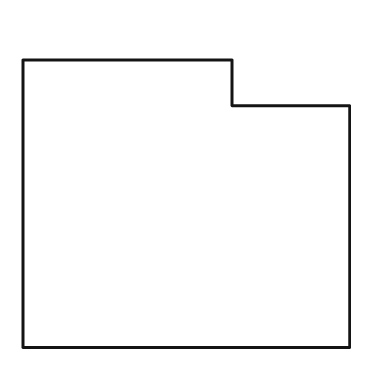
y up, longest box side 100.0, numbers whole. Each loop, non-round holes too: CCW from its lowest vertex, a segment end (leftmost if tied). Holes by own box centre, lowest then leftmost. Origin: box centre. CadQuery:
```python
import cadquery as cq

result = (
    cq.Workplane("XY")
    .moveTo(-50.0, -44.0)
    .lineTo(50.0, -44.0)
    .lineTo(50.0, 30.0)
    .lineTo(14.0, 30.0)
    .lineTo(14.0, 44.0)
    .lineTo(-50.0, 44.0)
    .close()
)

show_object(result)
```